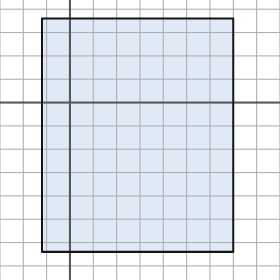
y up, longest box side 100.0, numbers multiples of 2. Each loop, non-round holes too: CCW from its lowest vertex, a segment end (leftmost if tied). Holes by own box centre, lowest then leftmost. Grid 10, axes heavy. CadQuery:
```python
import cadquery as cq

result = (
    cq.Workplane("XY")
    .moveTo(-12.0, -64.0)
    .lineTo(70.0, -64.0)
    .lineTo(70.0, 36.0)
    .lineTo(-12.0, 36.0)
    .close()
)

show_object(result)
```